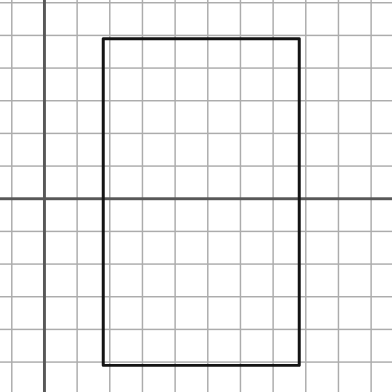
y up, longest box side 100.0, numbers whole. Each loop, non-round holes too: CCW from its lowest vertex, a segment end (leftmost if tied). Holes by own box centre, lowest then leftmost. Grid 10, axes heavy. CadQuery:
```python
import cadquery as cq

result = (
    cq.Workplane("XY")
    .moveTo(18.0, -51.0)
    .lineTo(78.0, -51.0)
    .lineTo(78.0, 49.0)
    .lineTo(18.0, 49.0)
    .close()
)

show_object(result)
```